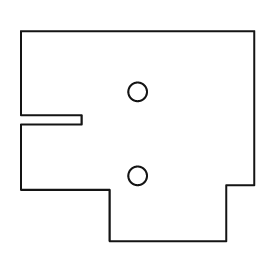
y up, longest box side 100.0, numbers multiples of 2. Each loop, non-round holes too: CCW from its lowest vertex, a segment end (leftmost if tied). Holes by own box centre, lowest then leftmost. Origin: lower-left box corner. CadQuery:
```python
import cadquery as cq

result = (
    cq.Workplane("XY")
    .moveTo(38.0, 0.0)
    .lineTo(88.0, 0.0)
    .lineTo(88.0, 24.0)
    .lineTo(100.0, 24.0)
    .lineTo(100.0, 90.0)
    .lineTo(0.0, 90.0)
    .lineTo(0.0, 54.0)
    .lineTo(26.0, 54.0)
    .lineTo(26.0, 50.0)
    .lineTo(0.0, 50.0)
    .lineTo(0.0, 22.0)
    .lineTo(38.0, 22.0)
    .close()
    .moveTo(50.0, 28.0)
    .circle(4.0)
    .moveTo(50.0, 64.0)
    .circle(4.0)
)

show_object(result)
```